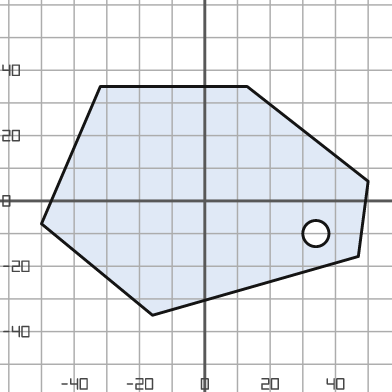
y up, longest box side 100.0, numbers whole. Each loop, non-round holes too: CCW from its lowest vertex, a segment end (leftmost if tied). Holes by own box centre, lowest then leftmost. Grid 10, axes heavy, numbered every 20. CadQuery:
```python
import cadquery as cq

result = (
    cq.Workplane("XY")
    .moveTo(-16.0, -35.0)
    .lineTo(47.0, -17.0)
    .lineTo(50.0, 6.0)
    .lineTo(13.0, 35.0)
    .lineTo(-32.0, 35.0)
    .lineTo(-50.0, -7.0)
    .close()
    .moveTo(34.0, -10.0)
    .circle(4.0)
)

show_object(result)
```